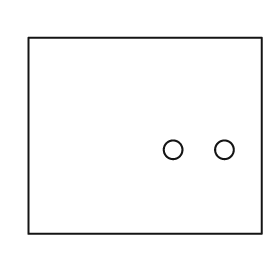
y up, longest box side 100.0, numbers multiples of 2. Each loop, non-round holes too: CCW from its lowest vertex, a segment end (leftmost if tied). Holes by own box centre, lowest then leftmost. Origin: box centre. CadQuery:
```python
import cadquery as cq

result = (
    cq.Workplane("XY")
    .moveTo(-50.0, -42.0)
    .lineTo(50.0, -42.0)
    .lineTo(50.0, 42.0)
    .lineTo(-50.0, 42.0)
    .close()
    .moveTo(12.0, -6.0)
    .circle(4.0)
    .moveTo(34.0, -6.0)
    .circle(4.0)
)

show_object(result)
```